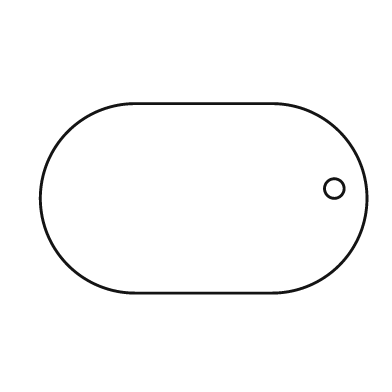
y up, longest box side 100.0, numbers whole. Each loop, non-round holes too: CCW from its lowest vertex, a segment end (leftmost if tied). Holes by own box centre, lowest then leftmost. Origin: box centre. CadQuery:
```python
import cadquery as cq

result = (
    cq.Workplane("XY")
    .moveTo(-21.0, -29.0)
    .lineTo(21.0, -29.0)
    .threePointArc((50.0, 0.0), (21.0, 29.0))
    .lineTo(-21.0, 29.0)
    .threePointArc((-50.0, 0.0), (-21.0, -29.0))
    .close()
    .moveTo(40.0, 3.0)
    .circle(3.0)
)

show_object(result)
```